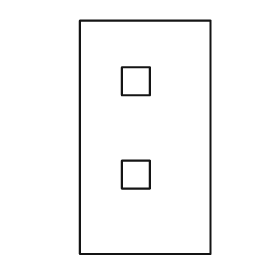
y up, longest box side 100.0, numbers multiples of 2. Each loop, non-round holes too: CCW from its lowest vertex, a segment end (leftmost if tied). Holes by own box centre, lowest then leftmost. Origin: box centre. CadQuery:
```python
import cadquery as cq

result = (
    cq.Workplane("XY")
    .moveTo(-28.0, -50.0)
    .lineTo(28.0, -50.0)
    .lineTo(28.0, 50.0)
    .lineTo(-28.0, 50.0)
    .close()
    .moveTo(-10.0, -22.0)
    .lineTo(2.0, -22.0)
    .lineTo(2.0, -10.0)
    .lineTo(-10.0, -10.0)
    .close()
    .moveTo(-10.0, 18.0)
    .lineTo(2.0, 18.0)
    .lineTo(2.0, 30.0)
    .lineTo(-10.0, 30.0)
    .close()
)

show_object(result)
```